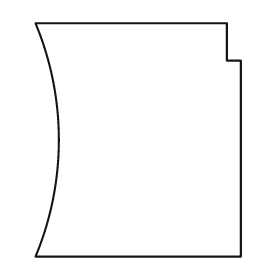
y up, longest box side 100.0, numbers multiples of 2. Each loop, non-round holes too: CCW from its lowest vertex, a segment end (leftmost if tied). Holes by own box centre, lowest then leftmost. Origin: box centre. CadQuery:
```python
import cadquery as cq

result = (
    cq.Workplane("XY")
    .moveTo(-44.0, -50.0)
    .lineTo(44.0, -50.0)
    .lineTo(44.0, 34.0)
    .lineTo(38.0, 34.0)
    .lineTo(38.0, 50.0)
    .lineTo(-44.0, 50.0)
    .threePointArc((-34.0, 0.0), (-44.0, -50.0))
    .close()
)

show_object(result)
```